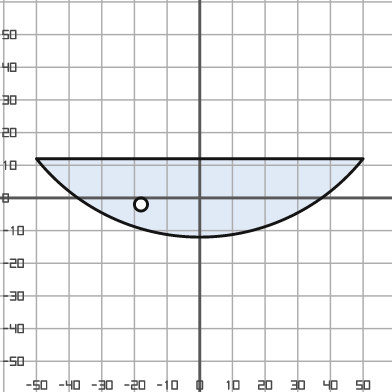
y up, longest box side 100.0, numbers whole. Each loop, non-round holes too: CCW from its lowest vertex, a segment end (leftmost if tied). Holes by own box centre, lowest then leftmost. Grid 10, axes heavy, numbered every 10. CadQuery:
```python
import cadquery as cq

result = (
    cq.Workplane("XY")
    .moveTo(-50.0, 12.0)
    .threePointArc((0.0, -12.0), (50.0, 12.0))
    .close()
    .moveTo(-18.0, -2.0)
    .circle(2.0)
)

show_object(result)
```